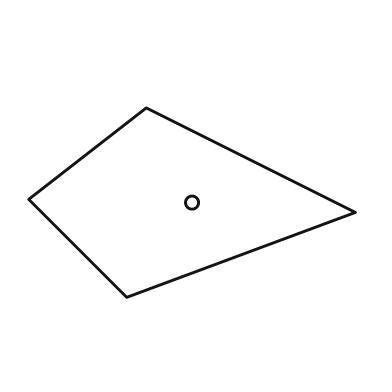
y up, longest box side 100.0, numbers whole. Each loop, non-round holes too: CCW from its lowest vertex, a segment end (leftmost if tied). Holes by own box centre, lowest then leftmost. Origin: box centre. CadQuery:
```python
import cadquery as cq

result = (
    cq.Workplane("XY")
    .moveTo(-20.0, -29.0)
    .lineTo(50.0, -3.0)
    .lineTo(-14.0, 29.0)
    .lineTo(-50.0, 1.0)
    .close()
    .moveTo(0.0, 0.0)
    .circle(2.0)
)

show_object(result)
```